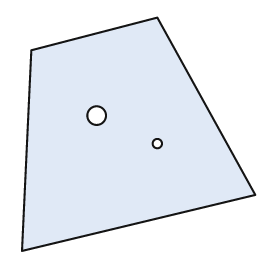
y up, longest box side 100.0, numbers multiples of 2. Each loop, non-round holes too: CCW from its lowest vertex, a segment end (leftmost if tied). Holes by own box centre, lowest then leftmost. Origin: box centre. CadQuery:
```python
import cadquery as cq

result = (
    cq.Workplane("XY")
    .moveTo(-50.0, -50.0)
    .lineTo(50.0, -26.0)
    .lineTo(8.0, 50.0)
    .lineTo(-46.0, 36.0)
    .close()
    .moveTo(8.0, -4.0)
    .circle(2.0)
    .moveTo(-18.0, 8.0)
    .circle(4.0)
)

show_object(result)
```